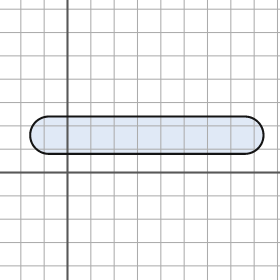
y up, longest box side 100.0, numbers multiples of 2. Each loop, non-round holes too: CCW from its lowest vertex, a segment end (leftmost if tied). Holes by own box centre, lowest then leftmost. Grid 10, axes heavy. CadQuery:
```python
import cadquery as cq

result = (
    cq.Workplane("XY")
    .moveTo(-8.0, 8.0)
    .lineTo(76.0, 8.0)
    .threePointArc((84.0, 16.0), (76.0, 24.0))
    .lineTo(-8.0, 24.0)
    .threePointArc((-16.0, 16.0), (-8.0, 8.0))
    .close()
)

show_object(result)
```